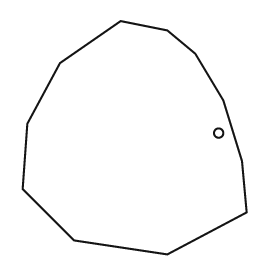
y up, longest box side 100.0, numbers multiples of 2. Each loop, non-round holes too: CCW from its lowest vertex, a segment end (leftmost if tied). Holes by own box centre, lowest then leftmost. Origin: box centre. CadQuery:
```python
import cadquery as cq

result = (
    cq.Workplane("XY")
    .moveTo(14.0, -50.0)
    .lineTo(48.0, -32.0)
    .lineTo(46.0, -10.0)
    .lineTo(38.0, 16.0)
    .lineTo(26.0, 36.0)
    .lineTo(14.0, 46.0)
    .lineTo(-6.0, 50.0)
    .lineTo(-32.0, 32.0)
    .lineTo(-46.0, 6.0)
    .lineTo(-48.0, -22.0)
    .lineTo(-26.0, -44.0)
    .close()
    .moveTo(36.0, 2.0)
    .circle(2.0)
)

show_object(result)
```